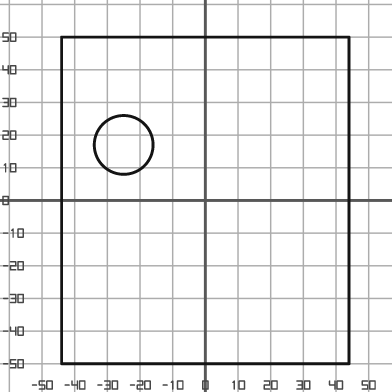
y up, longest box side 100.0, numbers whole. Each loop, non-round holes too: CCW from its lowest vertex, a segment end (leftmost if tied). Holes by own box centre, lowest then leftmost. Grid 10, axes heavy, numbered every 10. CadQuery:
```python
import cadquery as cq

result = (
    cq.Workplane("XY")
    .moveTo(-44.0, -50.0)
    .lineTo(44.0, -50.0)
    .lineTo(44.0, 50.0)
    .lineTo(-44.0, 50.0)
    .close()
    .moveTo(-25.0, 17.0)
    .circle(9.0)
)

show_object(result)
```